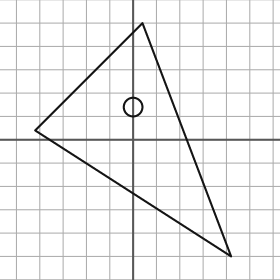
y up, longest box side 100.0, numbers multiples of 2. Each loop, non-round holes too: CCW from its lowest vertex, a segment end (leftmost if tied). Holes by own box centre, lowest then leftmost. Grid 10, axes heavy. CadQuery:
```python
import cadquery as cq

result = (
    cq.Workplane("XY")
    .moveTo(42.0, -50.0)
    .lineTo(4.0, 50.0)
    .lineTo(-42.0, 4.0)
    .close()
    .moveTo(0.0, 14.0)
    .circle(4.0)
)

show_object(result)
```